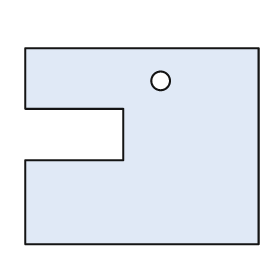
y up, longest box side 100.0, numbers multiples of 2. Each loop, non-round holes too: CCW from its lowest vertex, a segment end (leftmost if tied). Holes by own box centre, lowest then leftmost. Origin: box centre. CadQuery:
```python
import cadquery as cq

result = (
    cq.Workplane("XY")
    .moveTo(-50.0, -42.0)
    .lineTo(50.0, -42.0)
    .lineTo(50.0, 42.0)
    .lineTo(-50.0, 42.0)
    .lineTo(-50.0, 16.0)
    .lineTo(-8.0, 16.0)
    .lineTo(-8.0, -6.0)
    .lineTo(-50.0, -6.0)
    .close()
    .moveTo(8.0, 28.0)
    .circle(4.0)
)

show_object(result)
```